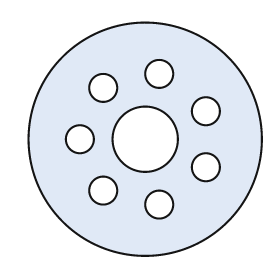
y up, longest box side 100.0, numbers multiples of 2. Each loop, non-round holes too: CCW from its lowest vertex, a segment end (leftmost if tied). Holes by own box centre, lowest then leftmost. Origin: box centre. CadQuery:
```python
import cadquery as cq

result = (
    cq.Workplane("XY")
    .moveTo(0.0, 0.0)
    .circle(50.0)
    .moveTo(6.0, -28.0)
    .circle(6.0)
    .moveTo(-18.0, -22.0)
    .circle(6.0)
    .moveTo(26.0, -12.0)
    .circle(6.0)
    .moveTo(-28.0, 0.0)
    .circle(6.0)
    .moveTo(0.0, 0.0)
    .circle(14.0)
    .moveTo(26.0, 12.0)
    .circle(6.0)
    .moveTo(-18.0, 22.0)
    .circle(6.0)
    .moveTo(6.0, 28.0)
    .circle(6.0)
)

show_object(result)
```